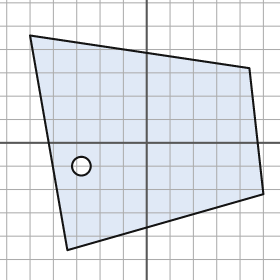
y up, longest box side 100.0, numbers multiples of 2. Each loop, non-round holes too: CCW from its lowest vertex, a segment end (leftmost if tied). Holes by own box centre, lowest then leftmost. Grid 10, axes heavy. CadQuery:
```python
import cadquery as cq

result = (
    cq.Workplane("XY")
    .moveTo(-34.0, -46.0)
    .lineTo(50.0, -22.0)
    .lineTo(44.0, 32.0)
    .lineTo(-50.0, 46.0)
    .close()
    .moveTo(-28.0, -10.0)
    .circle(4.0)
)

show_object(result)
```